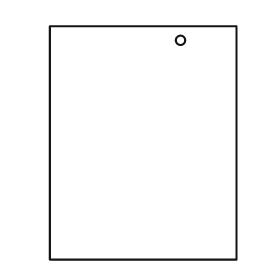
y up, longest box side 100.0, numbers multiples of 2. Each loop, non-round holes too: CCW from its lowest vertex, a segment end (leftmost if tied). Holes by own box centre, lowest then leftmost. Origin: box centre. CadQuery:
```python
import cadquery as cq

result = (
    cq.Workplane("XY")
    .moveTo(-40.0, -50.0)
    .lineTo(40.0, -50.0)
    .lineTo(40.0, 50.0)
    .lineTo(-40.0, 50.0)
    .close()
    .moveTo(16.0, 44.0)
    .circle(2.0)
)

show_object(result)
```